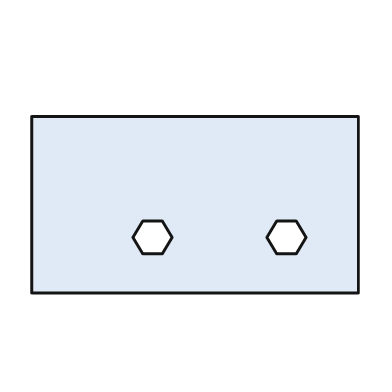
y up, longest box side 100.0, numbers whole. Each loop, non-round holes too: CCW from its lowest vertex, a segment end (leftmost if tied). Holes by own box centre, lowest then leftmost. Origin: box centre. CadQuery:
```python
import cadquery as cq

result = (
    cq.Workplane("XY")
    .moveTo(-50.0, -27.0)
    .lineTo(50.0, -27.0)
    .lineTo(50.0, 27.0)
    .lineTo(-50.0, 27.0)
    .close()
    .moveTo(-16.0, -15.0)
    .lineTo(-10.0, -15.0)
    .lineTo(-7.0, -10.0)
    .lineTo(-10.0, -5.0)
    .lineTo(-16.0, -5.0)
    .lineTo(-19.0, -10.0)
    .close()
    .moveTo(25.0, -15.0)
    .lineTo(31.0, -15.0)
    .lineTo(34.0, -10.0)
    .lineTo(31.0, -5.0)
    .lineTo(25.0, -5.0)
    .lineTo(22.0, -10.0)
    .close()
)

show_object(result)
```